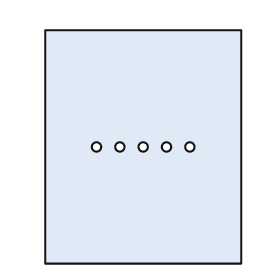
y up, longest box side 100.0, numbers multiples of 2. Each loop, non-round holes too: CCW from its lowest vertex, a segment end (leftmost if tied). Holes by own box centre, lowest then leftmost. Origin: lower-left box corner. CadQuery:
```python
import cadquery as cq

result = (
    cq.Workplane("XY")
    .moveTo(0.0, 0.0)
    .lineTo(84.0, 0.0)
    .lineTo(84.0, 100.0)
    .lineTo(0.0, 100.0)
    .close()
    .moveTo(22.0, 50.0)
    .circle(2.0)
    .moveTo(32.0, 50.0)
    .circle(2.0)
    .moveTo(42.0, 50.0)
    .circle(2.0)
    .moveTo(52.0, 50.0)
    .circle(2.0)
    .moveTo(62.0, 50.0)
    .circle(2.0)
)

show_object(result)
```